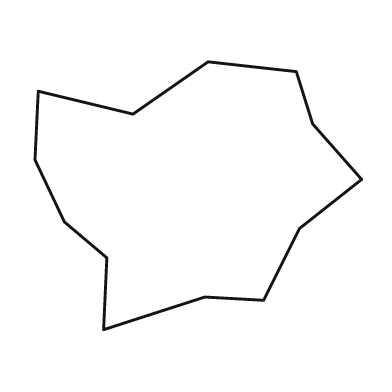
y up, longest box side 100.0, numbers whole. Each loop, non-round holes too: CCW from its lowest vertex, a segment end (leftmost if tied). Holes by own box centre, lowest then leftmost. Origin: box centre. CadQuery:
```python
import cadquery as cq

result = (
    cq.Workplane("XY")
    .moveTo(-29.0, -41.0)
    .lineTo(2.0, -31.0)
    .lineTo(20.0, -32.0)
    .lineTo(31.0, -10.0)
    .lineTo(50.0, 5.0)
    .lineTo(35.0, 22.0)
    .lineTo(30.0, 38.0)
    .lineTo(3.0, 41.0)
    .lineTo(-20.0, 25.0)
    .lineTo(-49.0, 32.0)
    .lineTo(-50.0, 11.0)
    .lineTo(-41.0, -8.0)
    .lineTo(-28.0, -19.0)
    .close()
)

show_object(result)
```